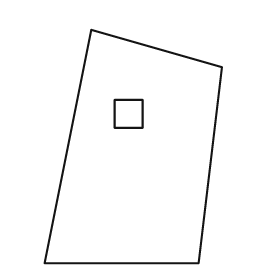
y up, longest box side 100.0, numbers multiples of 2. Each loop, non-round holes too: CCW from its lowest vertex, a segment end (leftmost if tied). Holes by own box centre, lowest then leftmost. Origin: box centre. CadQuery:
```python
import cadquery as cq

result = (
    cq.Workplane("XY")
    .moveTo(-38.0, -50.0)
    .lineTo(28.0, -50.0)
    .lineTo(38.0, 34.0)
    .lineTo(-18.0, 50.0)
    .close()
    .moveTo(-8.0, 8.0)
    .lineTo(4.0, 8.0)
    .lineTo(4.0, 20.0)
    .lineTo(-8.0, 20.0)
    .close()
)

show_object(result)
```